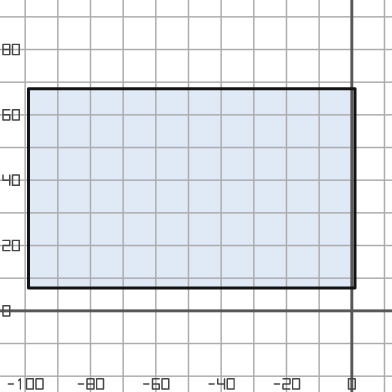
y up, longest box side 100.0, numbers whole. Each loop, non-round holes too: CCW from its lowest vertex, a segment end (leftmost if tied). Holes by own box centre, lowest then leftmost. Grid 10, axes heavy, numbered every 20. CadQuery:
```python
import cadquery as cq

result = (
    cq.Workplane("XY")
    .moveTo(-99.0, 7.0)
    .lineTo(1.0, 7.0)
    .lineTo(1.0, 68.0)
    .lineTo(-99.0, 68.0)
    .close()
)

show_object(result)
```